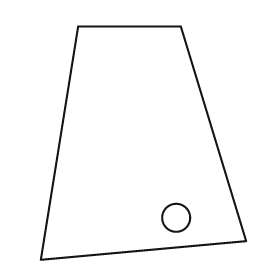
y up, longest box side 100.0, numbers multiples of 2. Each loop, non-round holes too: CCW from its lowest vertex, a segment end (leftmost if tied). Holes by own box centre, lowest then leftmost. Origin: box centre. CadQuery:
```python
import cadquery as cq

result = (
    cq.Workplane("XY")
    .moveTo(-44.0, -50.0)
    .lineTo(44.0, -42.0)
    .lineTo(16.0, 50.0)
    .lineTo(-28.0, 50.0)
    .close()
    .moveTo(14.0, -32.0)
    .circle(6.0)
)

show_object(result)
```